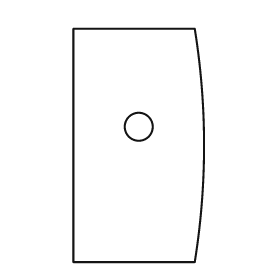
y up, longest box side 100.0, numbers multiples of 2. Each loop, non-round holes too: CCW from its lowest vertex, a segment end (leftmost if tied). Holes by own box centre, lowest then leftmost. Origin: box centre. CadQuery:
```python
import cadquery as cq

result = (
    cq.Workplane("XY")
    .moveTo(-28.0, -50.0)
    .lineTo(24.0, -50.0)
    .threePointArc((28.0, 0.0), (24.0, 50.0))
    .lineTo(-28.0, 50.0)
    .close()
    .moveTo(0.0, 8.0)
    .circle(6.0)
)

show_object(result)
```